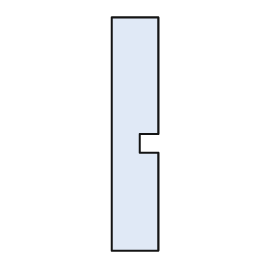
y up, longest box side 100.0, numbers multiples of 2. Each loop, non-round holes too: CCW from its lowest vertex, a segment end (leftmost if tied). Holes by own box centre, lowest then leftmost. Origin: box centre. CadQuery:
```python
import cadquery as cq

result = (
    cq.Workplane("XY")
    .moveTo(-10.0, -50.0)
    .lineTo(10.0, -50.0)
    .lineTo(10.0, -8.0)
    .lineTo(2.0, -8.0)
    .lineTo(2.0, 0.0)
    .lineTo(10.0, 0.0)
    .lineTo(10.0, 50.0)
    .lineTo(-10.0, 50.0)
    .close()
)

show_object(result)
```